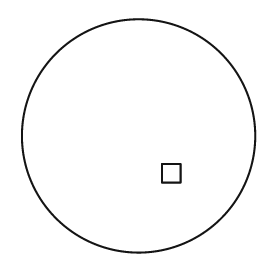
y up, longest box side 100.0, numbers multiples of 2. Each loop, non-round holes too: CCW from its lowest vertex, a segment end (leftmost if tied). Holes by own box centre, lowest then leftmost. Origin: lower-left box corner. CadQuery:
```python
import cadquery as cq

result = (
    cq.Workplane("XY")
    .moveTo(50.0, 50.0)
    .circle(50.0)
    .moveTo(60.0, 30.0)
    .lineTo(68.0, 30.0)
    .lineTo(68.0, 38.0)
    .lineTo(60.0, 38.0)
    .close()
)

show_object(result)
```